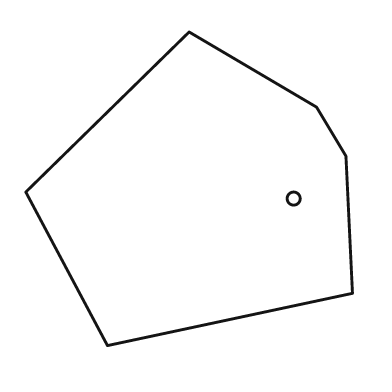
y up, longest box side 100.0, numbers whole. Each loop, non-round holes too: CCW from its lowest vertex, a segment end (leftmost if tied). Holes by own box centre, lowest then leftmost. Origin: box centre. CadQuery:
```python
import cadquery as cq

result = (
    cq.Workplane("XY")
    .moveTo(-25.0, -48.0)
    .lineTo(50.0, -32.0)
    .lineTo(48.0, 10.0)
    .lineTo(39.0, 25.0)
    .lineTo(0.0, 48.0)
    .lineTo(-50.0, -1.0)
    .close()
    .moveTo(32.0, -3.0)
    .circle(2.0)
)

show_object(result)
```